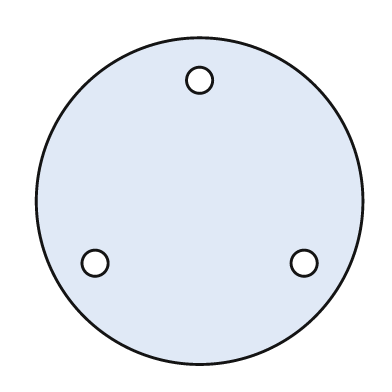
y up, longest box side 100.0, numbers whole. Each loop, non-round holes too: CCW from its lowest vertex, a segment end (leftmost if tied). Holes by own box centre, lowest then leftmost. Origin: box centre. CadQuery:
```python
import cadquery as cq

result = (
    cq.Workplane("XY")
    .moveTo(0.0, 0.0)
    .circle(50.0)
    .moveTo(-32.0, -19.0)
    .circle(4.0)
    .moveTo(32.0, -19.0)
    .circle(4.0)
    .moveTo(0.0, 37.0)
    .circle(4.0)
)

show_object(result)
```